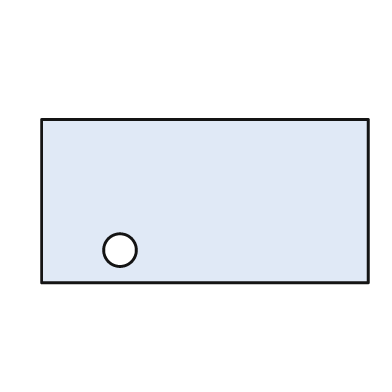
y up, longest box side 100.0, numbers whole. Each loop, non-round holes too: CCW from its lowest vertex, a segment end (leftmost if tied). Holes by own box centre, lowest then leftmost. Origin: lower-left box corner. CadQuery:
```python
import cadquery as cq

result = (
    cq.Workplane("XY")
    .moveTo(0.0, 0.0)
    .lineTo(100.0, 0.0)
    .lineTo(100.0, 50.0)
    .lineTo(0.0, 50.0)
    .close()
    .moveTo(24.0, 10.0)
    .circle(5.0)
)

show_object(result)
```